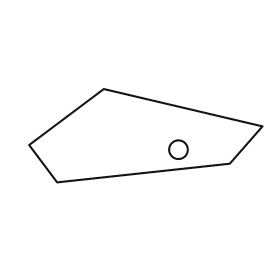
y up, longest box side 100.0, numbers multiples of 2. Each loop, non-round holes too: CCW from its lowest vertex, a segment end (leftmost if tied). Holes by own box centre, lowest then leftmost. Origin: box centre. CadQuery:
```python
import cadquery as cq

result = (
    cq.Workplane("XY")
    .moveTo(-38.0, -20.0)
    .lineTo(36.0, -12.0)
    .lineTo(50.0, 4.0)
    .lineTo(-18.0, 20.0)
    .lineTo(-50.0, -4.0)
    .close()
    .moveTo(14.0, -6.0)
    .circle(4.0)
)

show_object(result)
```